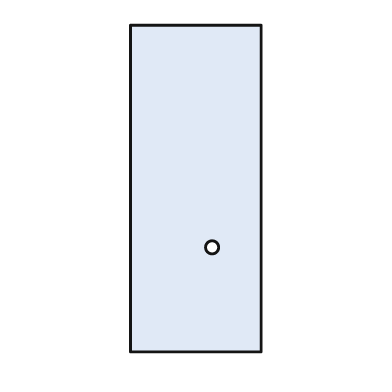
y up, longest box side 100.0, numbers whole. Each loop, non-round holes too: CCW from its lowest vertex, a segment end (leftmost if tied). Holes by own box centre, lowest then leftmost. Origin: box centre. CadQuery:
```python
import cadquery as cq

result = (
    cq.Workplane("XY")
    .moveTo(-20.0, -50.0)
    .lineTo(20.0, -50.0)
    .lineTo(20.0, 50.0)
    .lineTo(-20.0, 50.0)
    .close()
    .moveTo(5.0, -18.0)
    .circle(2.0)
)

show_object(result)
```